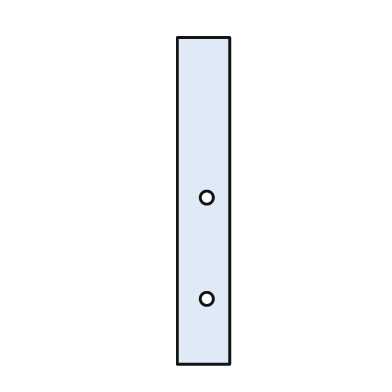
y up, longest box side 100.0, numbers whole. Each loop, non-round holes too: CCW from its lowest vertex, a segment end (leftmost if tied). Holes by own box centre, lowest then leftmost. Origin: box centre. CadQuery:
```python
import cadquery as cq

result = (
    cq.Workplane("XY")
    .moveTo(-8.0, -50.0)
    .lineTo(8.0, -50.0)
    .lineTo(8.0, 50.0)
    .lineTo(-8.0, 50.0)
    .close()
    .moveTo(1.0, -30.0)
    .circle(2.0)
    .moveTo(1.0, 1.0)
    .circle(2.0)
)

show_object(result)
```